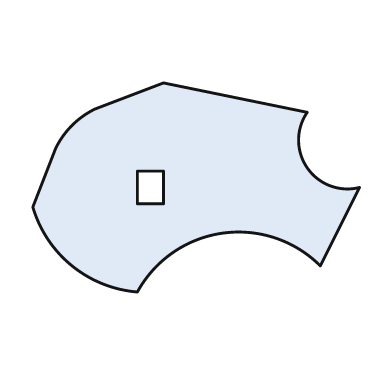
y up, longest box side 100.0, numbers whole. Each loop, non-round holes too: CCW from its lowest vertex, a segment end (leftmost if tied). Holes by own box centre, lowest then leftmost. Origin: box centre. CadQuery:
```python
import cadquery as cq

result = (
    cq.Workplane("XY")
    .moveTo(-18.0, -32.0)
    .threePointArc((8.0, -14.0), (38.0, -24.0))
    .lineTo(50.0, 0.0)
    .threePointArc((34.0, 6.0), (34.0, 23.0))
    .lineTo(-10.0, 32.0)
    .lineTo(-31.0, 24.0)
    .threePointArc((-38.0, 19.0), (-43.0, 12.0))
    .lineTo(-50.0, -6.0)
    .threePointArc((-38.0, -24.0), (-18.0, -32.0))
    .close()
    .moveTo(-18.0, -5.0)
    .lineTo(-10.0, -5.0)
    .lineTo(-10.0, 5.0)
    .lineTo(-18.0, 5.0)
    .close()
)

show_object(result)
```